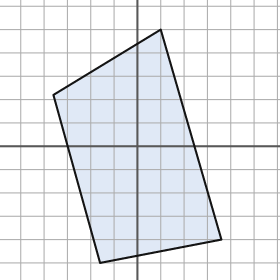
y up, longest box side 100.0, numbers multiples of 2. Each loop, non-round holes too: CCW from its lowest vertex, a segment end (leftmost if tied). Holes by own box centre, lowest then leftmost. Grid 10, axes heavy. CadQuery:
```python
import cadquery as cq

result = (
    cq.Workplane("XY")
    .moveTo(-16.0, -50.0)
    .lineTo(36.0, -40.0)
    .lineTo(10.0, 50.0)
    .lineTo(-36.0, 22.0)
    .close()
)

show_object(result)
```